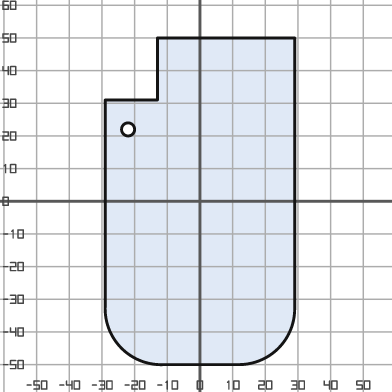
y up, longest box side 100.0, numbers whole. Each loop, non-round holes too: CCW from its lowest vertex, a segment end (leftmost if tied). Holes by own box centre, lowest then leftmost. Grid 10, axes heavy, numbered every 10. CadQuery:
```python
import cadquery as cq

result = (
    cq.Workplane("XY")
    .moveTo(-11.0, -50.0)
    .lineTo(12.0, -50.0)
    .threePointArc((24.0, -45.0), (29.0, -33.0))
    .lineTo(29.0, 50.0)
    .lineTo(-13.0, 50.0)
    .lineTo(-13.0, 31.0)
    .lineTo(-29.0, 31.0)
    .lineTo(-29.0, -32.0)
    .threePointArc((-24.0, -45.0), (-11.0, -50.0))
    .close()
    .moveTo(-22.0, 22.0)
    .circle(2.0)
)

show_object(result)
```